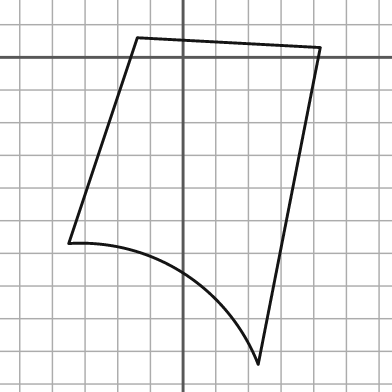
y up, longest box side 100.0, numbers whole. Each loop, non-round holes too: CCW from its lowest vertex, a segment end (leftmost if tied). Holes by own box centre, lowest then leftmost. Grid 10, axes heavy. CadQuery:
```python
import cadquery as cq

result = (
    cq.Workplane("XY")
    .moveTo(23.0, -94.0)
    .lineTo(42.0, 3.0)
    .lineTo(-14.0, 6.0)
    .lineTo(-35.0, -57.0)
    .threePointArc((0.0, -66.0), (23.0, -94.0))
    .close()
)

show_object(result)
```